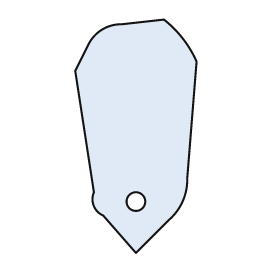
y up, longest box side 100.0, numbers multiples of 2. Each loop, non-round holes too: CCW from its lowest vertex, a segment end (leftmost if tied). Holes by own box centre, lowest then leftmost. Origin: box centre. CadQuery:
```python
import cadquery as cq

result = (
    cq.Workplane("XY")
    .moveTo(0.0, -50.0)
    .lineTo(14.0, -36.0)
    .threePointArc((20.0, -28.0), (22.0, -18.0))
    .lineTo(26.0, 32.0)
    .threePointArc((20.0, 42.0), (12.0, 50.0))
    .lineTo(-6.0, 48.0)
    .threePointArc((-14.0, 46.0), (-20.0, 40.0))
    .lineTo(-26.0, 28.0)
    .lineTo(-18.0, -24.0)
    .threePointArc((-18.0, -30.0), (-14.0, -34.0))
    .close()
    .moveTo(0.0, -28.0)
    .circle(4.0)
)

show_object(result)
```